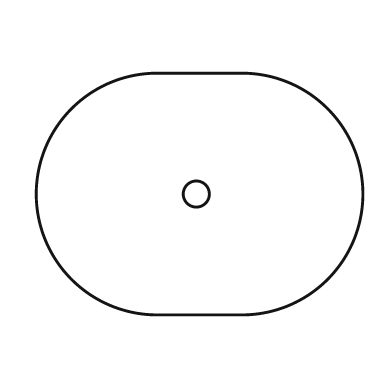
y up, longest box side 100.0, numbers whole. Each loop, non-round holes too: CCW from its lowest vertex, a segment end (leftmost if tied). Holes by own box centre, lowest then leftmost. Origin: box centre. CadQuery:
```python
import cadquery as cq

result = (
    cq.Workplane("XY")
    .moveTo(-13.0, -37.0)
    .lineTo(13.0, -37.0)
    .threePointArc((50.0, 0.0), (13.0, 37.0))
    .lineTo(-13.0, 37.0)
    .threePointArc((-50.0, 0.0), (-13.0, -37.0))
    .close()
    .moveTo(-1.0, 0.0)
    .circle(4.0)
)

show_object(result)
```